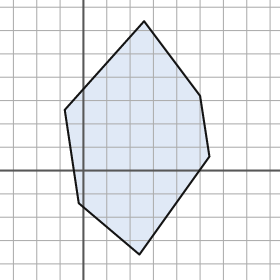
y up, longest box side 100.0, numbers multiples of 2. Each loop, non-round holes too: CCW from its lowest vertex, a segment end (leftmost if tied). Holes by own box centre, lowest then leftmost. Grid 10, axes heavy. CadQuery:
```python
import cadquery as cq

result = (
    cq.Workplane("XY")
    .moveTo(24.0, -36.0)
    .lineTo(54.0, 6.0)
    .lineTo(50.0, 32.0)
    .lineTo(26.0, 64.0)
    .lineTo(-8.0, 26.0)
    .lineTo(-2.0, -14.0)
    .close()
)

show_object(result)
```